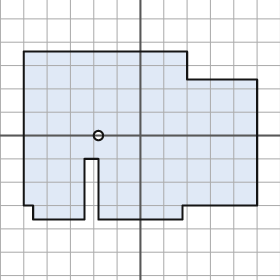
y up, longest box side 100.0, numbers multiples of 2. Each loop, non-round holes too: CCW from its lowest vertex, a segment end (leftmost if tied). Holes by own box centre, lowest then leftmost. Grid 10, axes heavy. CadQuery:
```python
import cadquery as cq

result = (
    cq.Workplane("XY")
    .moveTo(-46.0, -36.0)
    .lineTo(-24.0, -36.0)
    .lineTo(-24.0, -10.0)
    .lineTo(-18.0, -10.0)
    .lineTo(-18.0, -36.0)
    .lineTo(18.0, -36.0)
    .lineTo(18.0, -30.0)
    .lineTo(50.0, -30.0)
    .lineTo(50.0, 24.0)
    .lineTo(20.0, 24.0)
    .lineTo(20.0, 36.0)
    .lineTo(-50.0, 36.0)
    .lineTo(-50.0, -30.0)
    .lineTo(-46.0, -30.0)
    .close()
    .moveTo(-18.0, 0.0)
    .circle(2.0)
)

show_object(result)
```